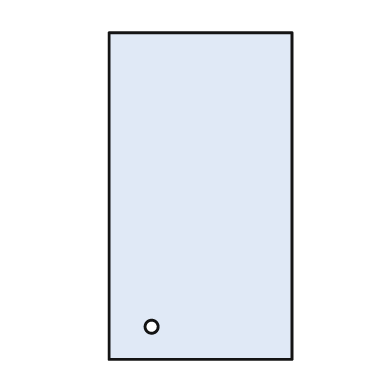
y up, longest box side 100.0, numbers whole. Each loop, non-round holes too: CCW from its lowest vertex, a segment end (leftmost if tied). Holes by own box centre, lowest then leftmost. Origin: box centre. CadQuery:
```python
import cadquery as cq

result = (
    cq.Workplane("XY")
    .moveTo(-28.0, -50.0)
    .lineTo(28.0, -50.0)
    .lineTo(28.0, 50.0)
    .lineTo(-28.0, 50.0)
    .close()
    .moveTo(-15.0, -40.0)
    .circle(2.0)
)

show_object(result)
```